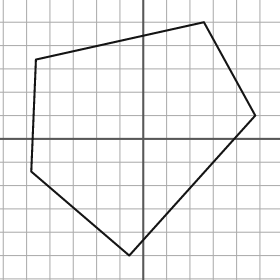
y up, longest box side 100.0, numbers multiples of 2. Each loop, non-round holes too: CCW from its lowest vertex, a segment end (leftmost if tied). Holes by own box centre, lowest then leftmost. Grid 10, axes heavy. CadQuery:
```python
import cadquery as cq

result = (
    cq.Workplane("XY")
    .moveTo(-6.0, -50.0)
    .lineTo(48.0, 10.0)
    .lineTo(26.0, 50.0)
    .lineTo(-46.0, 34.0)
    .lineTo(-48.0, -14.0)
    .close()
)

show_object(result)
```